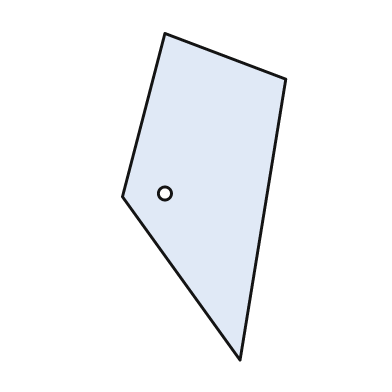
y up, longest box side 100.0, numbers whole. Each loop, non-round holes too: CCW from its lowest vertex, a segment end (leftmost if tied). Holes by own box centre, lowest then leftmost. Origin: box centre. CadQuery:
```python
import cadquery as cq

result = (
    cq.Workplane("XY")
    .moveTo(11.0, -50.0)
    .lineTo(25.0, 36.0)
    .lineTo(-12.0, 50.0)
    .lineTo(-25.0, 0.0)
    .close()
    .moveTo(-12.0, 1.0)
    .circle(2.0)
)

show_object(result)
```